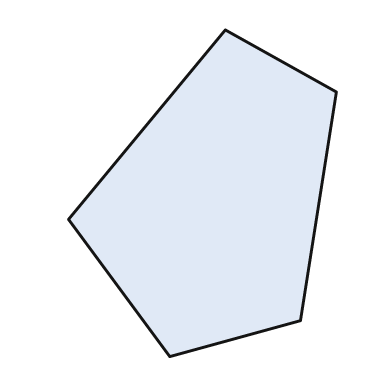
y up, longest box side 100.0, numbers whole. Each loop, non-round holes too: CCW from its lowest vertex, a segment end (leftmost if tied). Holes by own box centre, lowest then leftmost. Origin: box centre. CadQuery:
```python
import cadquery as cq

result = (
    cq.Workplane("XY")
    .moveTo(-10.0, -50.0)
    .lineTo(30.0, -39.0)
    .lineTo(41.0, 31.0)
    .lineTo(7.0, 50.0)
    .lineTo(-41.0, -8.0)
    .close()
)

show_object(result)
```